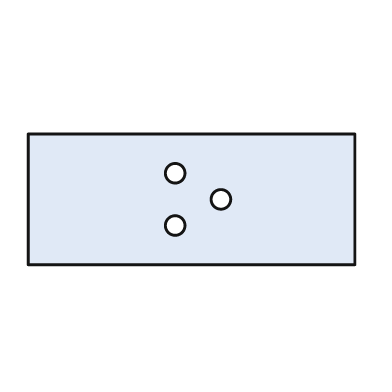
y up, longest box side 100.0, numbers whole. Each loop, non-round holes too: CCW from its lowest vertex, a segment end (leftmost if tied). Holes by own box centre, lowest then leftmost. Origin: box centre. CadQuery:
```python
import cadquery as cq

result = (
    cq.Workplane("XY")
    .moveTo(-50.0, -20.0)
    .lineTo(50.0, -20.0)
    .lineTo(50.0, 20.0)
    .lineTo(-50.0, 20.0)
    .close()
    .moveTo(-5.0, -8.0)
    .circle(3.0)
    .moveTo(9.0, 0.0)
    .circle(3.0)
    .moveTo(-5.0, 8.0)
    .circle(3.0)
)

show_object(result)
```